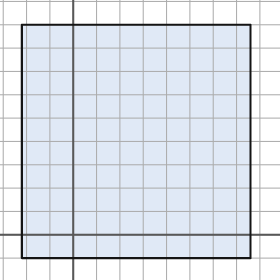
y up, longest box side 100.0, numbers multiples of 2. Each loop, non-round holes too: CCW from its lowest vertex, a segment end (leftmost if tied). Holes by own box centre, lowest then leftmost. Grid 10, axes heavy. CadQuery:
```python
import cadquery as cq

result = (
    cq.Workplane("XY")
    .moveTo(-22.0, -10.0)
    .lineTo(76.0, -10.0)
    .lineTo(76.0, 90.0)
    .lineTo(-22.0, 90.0)
    .close()
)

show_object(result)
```